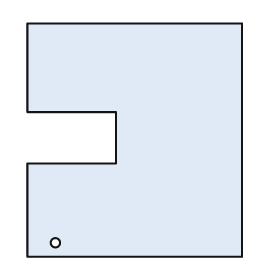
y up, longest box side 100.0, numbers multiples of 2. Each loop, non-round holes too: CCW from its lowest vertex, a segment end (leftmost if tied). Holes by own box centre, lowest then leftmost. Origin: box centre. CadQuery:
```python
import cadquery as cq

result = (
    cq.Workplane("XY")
    .moveTo(-46.0, -50.0)
    .lineTo(46.0, -50.0)
    .lineTo(46.0, 50.0)
    .lineTo(-46.0, 50.0)
    .lineTo(-46.0, 12.0)
    .lineTo(-8.0, 12.0)
    .lineTo(-8.0, -10.0)
    .lineTo(-46.0, -10.0)
    .close()
    .moveTo(-34.0, -44.0)
    .circle(2.0)
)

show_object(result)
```